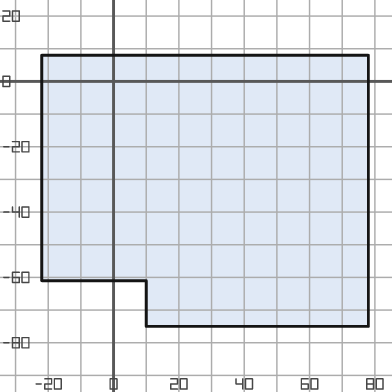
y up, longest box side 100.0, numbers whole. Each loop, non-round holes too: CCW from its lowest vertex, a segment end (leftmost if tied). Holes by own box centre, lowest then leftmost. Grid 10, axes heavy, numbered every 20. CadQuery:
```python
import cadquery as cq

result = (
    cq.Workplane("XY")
    .moveTo(10.0, -75.0)
    .lineTo(78.0, -75.0)
    .lineTo(78.0, 8.0)
    .lineTo(-22.0, 8.0)
    .lineTo(-22.0, -61.0)
    .lineTo(10.0, -61.0)
    .close()
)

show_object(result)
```